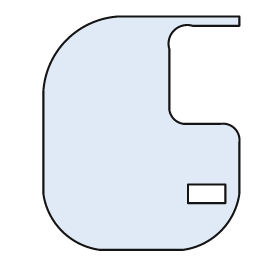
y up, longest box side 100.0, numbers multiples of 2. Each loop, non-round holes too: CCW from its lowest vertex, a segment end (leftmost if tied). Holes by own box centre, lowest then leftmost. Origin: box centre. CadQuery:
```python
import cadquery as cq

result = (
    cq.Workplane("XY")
    .moveTo(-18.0, -50.0)
    .lineTo(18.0, -50.0)
    .threePointArc((34.0, -42.0), (42.0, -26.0))
    .lineTo(42.0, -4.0)
    .threePointArc((40.0, 2.0), (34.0, 4.0))
    .lineTo(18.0, 4.0)
    .threePointArc((14.0, 6.0), (12.0, 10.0))
    .lineTo(12.0, 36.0)
    .threePointArc((14.0, 44.0), (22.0, 46.0))
    .lineTo(42.0, 46.0)
    .lineTo(42.0, 50.0)
    .lineTo(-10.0, 50.0)
    .threePointArc((-32.0, 40.0), (-42.0, 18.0))
    .lineTo(-42.0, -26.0)
    .threePointArc((-34.0, -42.0), (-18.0, -50.0))
    .close()
    .moveTo(20.0, -30.0)
    .lineTo(36.0, -30.0)
    .lineTo(36.0, -22.0)
    .lineTo(20.0, -22.0)
    .close()
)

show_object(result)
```